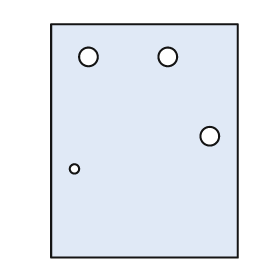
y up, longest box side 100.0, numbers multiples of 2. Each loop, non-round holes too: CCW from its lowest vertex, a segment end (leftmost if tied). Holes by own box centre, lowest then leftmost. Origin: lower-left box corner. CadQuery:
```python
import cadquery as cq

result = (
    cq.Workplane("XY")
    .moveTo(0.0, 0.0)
    .lineTo(80.0, 0.0)
    .lineTo(80.0, 100.0)
    .lineTo(0.0, 100.0)
    .close()
    .moveTo(10.0, 38.0)
    .circle(2.0)
    .moveTo(68.0, 52.0)
    .circle(4.0)
    .moveTo(16.0, 86.0)
    .circle(4.0)
    .moveTo(50.0, 86.0)
    .circle(4.0)
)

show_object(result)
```